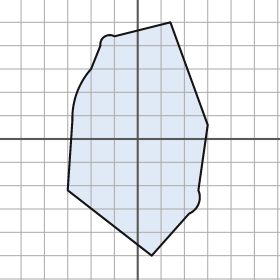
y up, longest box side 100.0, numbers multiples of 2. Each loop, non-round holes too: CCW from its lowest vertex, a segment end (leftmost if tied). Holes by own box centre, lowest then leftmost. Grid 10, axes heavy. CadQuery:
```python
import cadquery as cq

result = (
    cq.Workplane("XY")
    .moveTo(6.0, -50.0)
    .lineTo(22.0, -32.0)
    .threePointArc((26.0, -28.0), (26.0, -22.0))
    .lineTo(30.0, 6.0)
    .lineTo(14.0, 50.0)
    .lineTo(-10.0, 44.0)
    .threePointArc((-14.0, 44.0), (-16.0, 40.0))
    .lineTo(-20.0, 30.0)
    .threePointArc((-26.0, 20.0), (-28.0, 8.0))
    .lineTo(-30.0, -22.0)
    .close()
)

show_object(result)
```